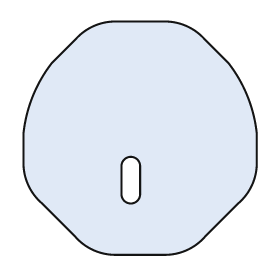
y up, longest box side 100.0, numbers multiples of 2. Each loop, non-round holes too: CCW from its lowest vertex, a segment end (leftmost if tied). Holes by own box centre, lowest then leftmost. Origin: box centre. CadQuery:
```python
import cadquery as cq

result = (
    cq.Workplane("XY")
    .moveTo(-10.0, -50.0)
    .lineTo(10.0, -50.0)
    .threePointArc((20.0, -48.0), (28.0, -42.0))
    .lineTo(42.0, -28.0)
    .threePointArc((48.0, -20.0), (50.0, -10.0))
    .lineTo(50.0, 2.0)
    .threePointArc((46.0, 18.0), (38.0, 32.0))
    .lineTo(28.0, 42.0)
    .threePointArc((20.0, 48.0), (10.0, 50.0))
    .lineTo(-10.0, 50.0)
    .threePointArc((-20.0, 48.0), (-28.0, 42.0))
    .lineTo(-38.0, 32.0)
    .threePointArc((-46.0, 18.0), (-50.0, 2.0))
    .lineTo(-50.0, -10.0)
    .threePointArc((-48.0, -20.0), (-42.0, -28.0))
    .lineTo(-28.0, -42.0)
    .threePointArc((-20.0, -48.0), (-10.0, -50.0))
    .close()
    .moveTo(-8.0, -24.0)
    .threePointArc((-4.0, -28.0), (0.0, -24.0))
    .lineTo(0.0, -12.0)
    .threePointArc((-4.0, -8.0), (-8.0, -12.0))
    .close()
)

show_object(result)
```